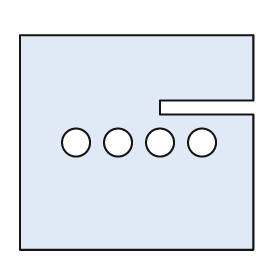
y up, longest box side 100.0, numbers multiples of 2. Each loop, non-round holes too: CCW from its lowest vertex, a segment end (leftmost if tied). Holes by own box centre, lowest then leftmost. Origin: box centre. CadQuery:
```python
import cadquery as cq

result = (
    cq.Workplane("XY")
    .moveTo(-50.0, -46.0)
    .lineTo(50.0, -46.0)
    .lineTo(50.0, 12.0)
    .lineTo(10.0, 12.0)
    .lineTo(10.0, 18.0)
    .lineTo(50.0, 18.0)
    .lineTo(50.0, 46.0)
    .lineTo(-50.0, 46.0)
    .close()
    .moveTo(-26.0, 0.0)
    .circle(6.0)
    .moveTo(-8.0, 0.0)
    .circle(6.0)
    .moveTo(10.0, 0.0)
    .circle(6.0)
    .moveTo(28.0, 0.0)
    .circle(6.0)
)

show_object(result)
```